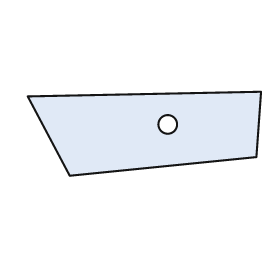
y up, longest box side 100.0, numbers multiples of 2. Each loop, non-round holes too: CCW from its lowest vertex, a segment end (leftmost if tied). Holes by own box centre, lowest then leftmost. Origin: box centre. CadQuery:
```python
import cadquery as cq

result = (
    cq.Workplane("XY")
    .moveTo(-32.0, -18.0)
    .lineTo(48.0, -10.0)
    .lineTo(50.0, 18.0)
    .lineTo(-50.0, 16.0)
    .close()
    .moveTo(10.0, 4.0)
    .circle(4.0)
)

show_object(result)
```